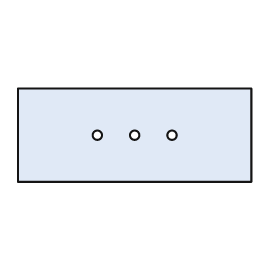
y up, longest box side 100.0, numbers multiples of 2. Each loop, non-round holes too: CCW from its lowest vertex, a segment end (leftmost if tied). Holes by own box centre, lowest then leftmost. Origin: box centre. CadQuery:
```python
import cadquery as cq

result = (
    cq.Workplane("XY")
    .moveTo(-50.0, -20.0)
    .lineTo(50.0, -20.0)
    .lineTo(50.0, 20.0)
    .lineTo(-50.0, 20.0)
    .close()
    .moveTo(-16.0, 0.0)
    .circle(2.0)
    .moveTo(0.0, 0.0)
    .circle(2.0)
    .moveTo(16.0, 0.0)
    .circle(2.0)
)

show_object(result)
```